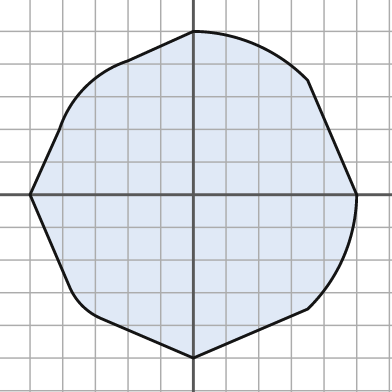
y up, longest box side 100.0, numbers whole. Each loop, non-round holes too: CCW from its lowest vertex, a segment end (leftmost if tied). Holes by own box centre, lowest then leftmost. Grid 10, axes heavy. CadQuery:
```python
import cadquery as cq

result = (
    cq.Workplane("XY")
    .moveTo(0.0, -50.0)
    .lineTo(35.0, -35.0)
    .threePointArc((46.0, -19.0), (50.0, 0.0))
    .lineTo(35.0, 35.0)
    .threePointArc((19.0, 46.0), (0.0, 50.0))
    .lineTo(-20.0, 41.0)
    .threePointArc((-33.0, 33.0), (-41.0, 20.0))
    .lineTo(-50.0, 0.0)
    .lineTo(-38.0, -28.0)
    .threePointArc((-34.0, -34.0), (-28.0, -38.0))
    .close()
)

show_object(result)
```